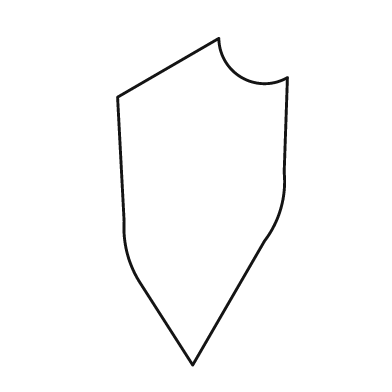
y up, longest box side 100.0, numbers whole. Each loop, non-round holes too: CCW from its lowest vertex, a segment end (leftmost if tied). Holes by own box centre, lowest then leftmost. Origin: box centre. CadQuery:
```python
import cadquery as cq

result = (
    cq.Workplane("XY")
    .moveTo(-3.0, -50.0)
    .lineTo(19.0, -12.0)
    .threePointArc((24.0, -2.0), (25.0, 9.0))
    .lineTo(26.0, 38.0)
    .threePointArc((12.0, 38.0), (5.0, 50.0))
    .lineTo(-26.0, 32.0)
    .lineTo(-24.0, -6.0)
    .threePointArc((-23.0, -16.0), (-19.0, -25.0))
    .close()
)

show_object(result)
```